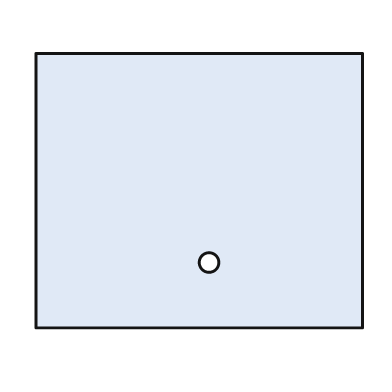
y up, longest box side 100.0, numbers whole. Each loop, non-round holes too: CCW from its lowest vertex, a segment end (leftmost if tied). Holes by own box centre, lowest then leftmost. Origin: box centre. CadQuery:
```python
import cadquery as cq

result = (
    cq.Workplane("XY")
    .moveTo(-50.0, -42.0)
    .lineTo(50.0, -42.0)
    .lineTo(50.0, 42.0)
    .lineTo(-50.0, 42.0)
    .close()
    .moveTo(3.0, -22.0)
    .circle(3.0)
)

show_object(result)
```